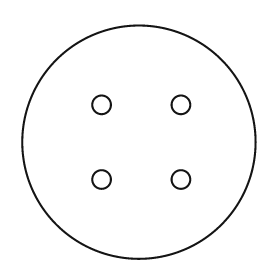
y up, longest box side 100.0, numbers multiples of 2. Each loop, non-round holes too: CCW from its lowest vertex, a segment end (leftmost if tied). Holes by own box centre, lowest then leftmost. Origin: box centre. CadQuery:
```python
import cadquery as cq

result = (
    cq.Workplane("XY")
    .moveTo(0.0, 0.0)
    .circle(50.0)
    .moveTo(-16.0, -16.0)
    .circle(4.0)
    .moveTo(18.0, -16.0)
    .circle(4.0)
    .moveTo(-16.0, 16.0)
    .circle(4.0)
    .moveTo(18.0, 16.0)
    .circle(4.0)
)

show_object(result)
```